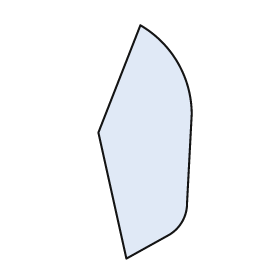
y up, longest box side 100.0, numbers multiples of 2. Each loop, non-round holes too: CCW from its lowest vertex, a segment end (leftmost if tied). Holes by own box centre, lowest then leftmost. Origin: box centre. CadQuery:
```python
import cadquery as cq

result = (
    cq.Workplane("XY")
    .moveTo(-8.0, -50.0)
    .lineTo(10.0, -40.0)
    .threePointArc((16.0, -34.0), (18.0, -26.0))
    .lineTo(20.0, 12.0)
    .threePointArc((14.0, 34.0), (-2.0, 50.0))
    .lineTo(-20.0, 4.0)
    .close()
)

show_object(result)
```